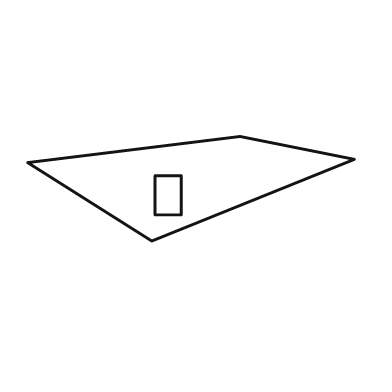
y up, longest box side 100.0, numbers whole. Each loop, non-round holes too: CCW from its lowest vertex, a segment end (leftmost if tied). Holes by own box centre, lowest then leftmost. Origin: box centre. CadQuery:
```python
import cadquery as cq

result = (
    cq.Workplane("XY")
    .moveTo(-12.0, -16.0)
    .lineTo(50.0, 9.0)
    .lineTo(15.0, 16.0)
    .lineTo(-50.0, 8.0)
    .close()
    .moveTo(-11.0, -8.0)
    .lineTo(-3.0, -8.0)
    .lineTo(-3.0, 4.0)
    .lineTo(-11.0, 4.0)
    .close()
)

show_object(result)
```